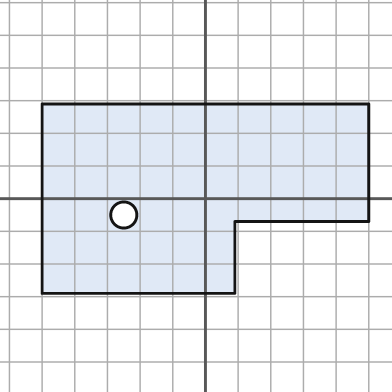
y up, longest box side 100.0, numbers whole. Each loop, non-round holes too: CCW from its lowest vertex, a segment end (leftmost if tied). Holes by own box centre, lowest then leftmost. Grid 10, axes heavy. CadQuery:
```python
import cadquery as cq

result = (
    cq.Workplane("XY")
    .moveTo(-50.0, -29.0)
    .lineTo(9.0, -29.0)
    .lineTo(9.0, -7.0)
    .lineTo(50.0, -7.0)
    .lineTo(50.0, 29.0)
    .lineTo(-50.0, 29.0)
    .close()
    .moveTo(-25.0, -5.0)
    .circle(4.0)
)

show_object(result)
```